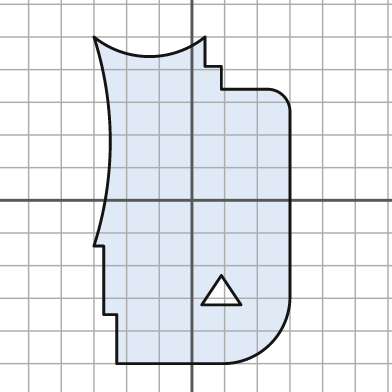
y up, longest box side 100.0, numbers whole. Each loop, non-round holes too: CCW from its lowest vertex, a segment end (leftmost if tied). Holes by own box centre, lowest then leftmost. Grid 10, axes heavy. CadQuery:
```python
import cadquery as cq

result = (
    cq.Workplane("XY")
    .moveTo(-23.0, -50.0)
    .lineTo(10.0, -50.0)
    .threePointArc((24.0, -44.0), (30.0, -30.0))
    .lineTo(30.0, 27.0)
    .threePointArc((28.0, 32.0), (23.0, 34.0))
    .lineTo(9.0, 34.0)
    .lineTo(9.0, 41.0)
    .lineTo(4.0, 41.0)
    .lineTo(4.0, 50.0)
    .threePointArc((-13.0, 44.0), (-30.0, 50.0))
    .threePointArc((-25.0, 18.0), (-30.0, -14.0))
    .lineTo(-27.0, -14.0)
    .lineTo(-27.0, -35.0)
    .lineTo(-23.0, -35.0)
    .close()
    .moveTo(3.0, -32.0)
    .lineTo(15.0, -32.0)
    .lineTo(9.0, -23.0)
    .close()
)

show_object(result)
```